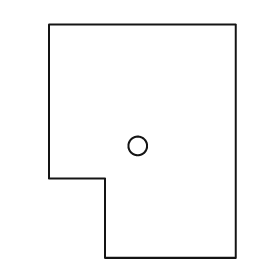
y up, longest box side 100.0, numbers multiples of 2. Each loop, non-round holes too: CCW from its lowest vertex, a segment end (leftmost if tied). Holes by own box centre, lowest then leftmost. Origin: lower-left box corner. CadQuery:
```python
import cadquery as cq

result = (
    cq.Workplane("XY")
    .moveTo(24.0, 0.0)
    .lineTo(80.0, 0.0)
    .lineTo(80.0, 100.0)
    .lineTo(0.0, 100.0)
    .lineTo(0.0, 34.0)
    .lineTo(24.0, 34.0)
    .close()
    .moveTo(38.0, 48.0)
    .circle(4.0)
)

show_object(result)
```